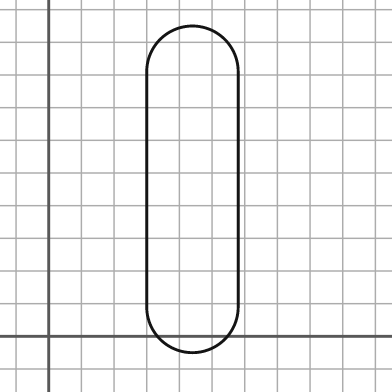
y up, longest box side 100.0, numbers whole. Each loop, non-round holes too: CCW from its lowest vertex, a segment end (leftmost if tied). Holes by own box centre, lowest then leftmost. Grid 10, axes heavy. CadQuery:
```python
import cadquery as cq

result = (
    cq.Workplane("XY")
    .moveTo(30.0, 9.0)
    .threePointArc((44.0, -5.0), (58.0, 9.0))
    .lineTo(58.0, 81.0)
    .threePointArc((44.0, 95.0), (30.0, 81.0))
    .close()
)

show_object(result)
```